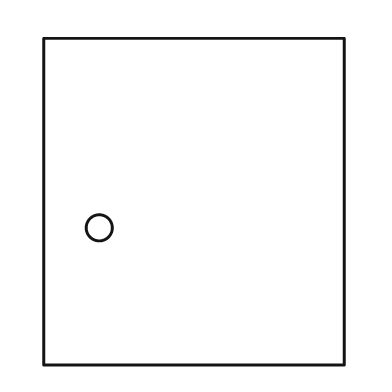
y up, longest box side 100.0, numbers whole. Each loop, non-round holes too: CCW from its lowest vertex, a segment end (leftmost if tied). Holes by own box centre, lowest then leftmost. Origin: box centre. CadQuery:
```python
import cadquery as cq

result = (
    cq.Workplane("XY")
    .moveTo(-46.0, -50.0)
    .lineTo(46.0, -50.0)
    .lineTo(46.0, 50.0)
    .lineTo(-46.0, 50.0)
    .close()
    .moveTo(-29.0, -8.0)
    .circle(4.0)
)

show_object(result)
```